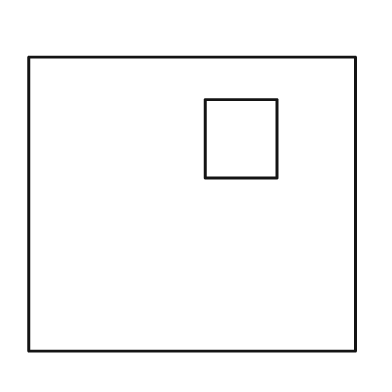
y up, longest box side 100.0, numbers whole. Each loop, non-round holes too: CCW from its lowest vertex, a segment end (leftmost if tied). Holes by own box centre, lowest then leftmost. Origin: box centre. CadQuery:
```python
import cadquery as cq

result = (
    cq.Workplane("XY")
    .moveTo(-50.0, -45.0)
    .lineTo(50.0, -45.0)
    .lineTo(50.0, 45.0)
    .lineTo(-50.0, 45.0)
    .close()
    .moveTo(4.0, 8.0)
    .lineTo(26.0, 8.0)
    .lineTo(26.0, 32.0)
    .lineTo(4.0, 32.0)
    .close()
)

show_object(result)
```